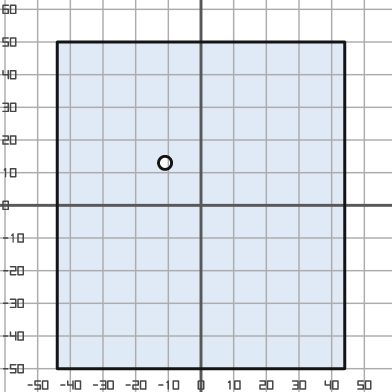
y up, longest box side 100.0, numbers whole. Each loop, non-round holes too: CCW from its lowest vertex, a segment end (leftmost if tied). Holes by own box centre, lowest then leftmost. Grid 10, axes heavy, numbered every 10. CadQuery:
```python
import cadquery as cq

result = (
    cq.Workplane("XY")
    .moveTo(-44.0, -50.0)
    .lineTo(44.0, -50.0)
    .lineTo(44.0, 50.0)
    .lineTo(-44.0, 50.0)
    .close()
    .moveTo(-11.0, 13.0)
    .circle(2.0)
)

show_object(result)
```